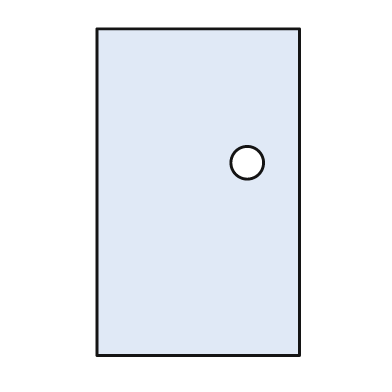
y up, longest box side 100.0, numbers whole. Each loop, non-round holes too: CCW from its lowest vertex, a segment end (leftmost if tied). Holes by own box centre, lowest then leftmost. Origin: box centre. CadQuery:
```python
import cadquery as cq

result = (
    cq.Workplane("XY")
    .moveTo(-31.0, -50.0)
    .lineTo(31.0, -50.0)
    .lineTo(31.0, 50.0)
    .lineTo(-31.0, 50.0)
    .close()
    .moveTo(15.0, 9.0)
    .circle(5.0)
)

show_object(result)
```